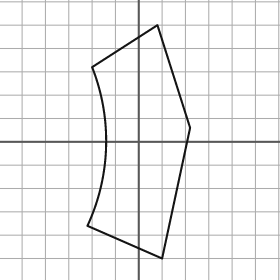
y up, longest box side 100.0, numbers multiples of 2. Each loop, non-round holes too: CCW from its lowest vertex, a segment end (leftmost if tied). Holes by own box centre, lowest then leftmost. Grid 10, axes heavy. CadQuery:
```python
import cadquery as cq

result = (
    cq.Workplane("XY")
    .moveTo(10.0, -50.0)
    .lineTo(22.0, 6.0)
    .lineTo(8.0, 50.0)
    .lineTo(-20.0, 32.0)
    .threePointArc((-14.0, -2.0), (-22.0, -36.0))
    .close()
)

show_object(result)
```